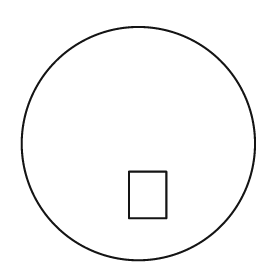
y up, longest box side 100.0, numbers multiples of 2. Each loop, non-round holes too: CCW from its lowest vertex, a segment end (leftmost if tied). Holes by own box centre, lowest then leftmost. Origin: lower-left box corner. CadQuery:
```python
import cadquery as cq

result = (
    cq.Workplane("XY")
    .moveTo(50.0, 50.0)
    .circle(50.0)
    .moveTo(46.0, 18.0)
    .lineTo(62.0, 18.0)
    .lineTo(62.0, 38.0)
    .lineTo(46.0, 38.0)
    .close()
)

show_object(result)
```